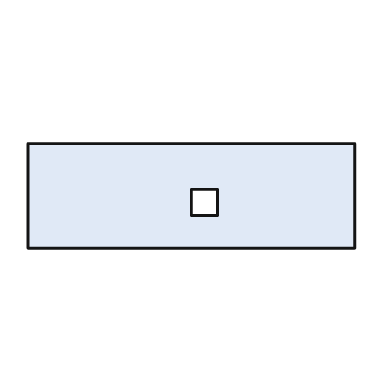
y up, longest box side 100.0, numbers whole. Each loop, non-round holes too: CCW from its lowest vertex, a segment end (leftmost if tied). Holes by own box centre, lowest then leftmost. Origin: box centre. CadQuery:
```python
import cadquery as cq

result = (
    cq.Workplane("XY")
    .moveTo(-50.0, -16.0)
    .lineTo(50.0, -16.0)
    .lineTo(50.0, 16.0)
    .lineTo(-50.0, 16.0)
    .close()
    .moveTo(0.0, -6.0)
    .lineTo(8.0, -6.0)
    .lineTo(8.0, 2.0)
    .lineTo(0.0, 2.0)
    .close()
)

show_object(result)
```